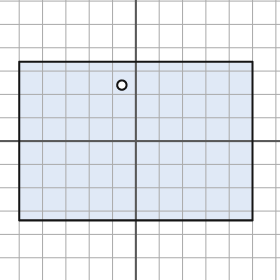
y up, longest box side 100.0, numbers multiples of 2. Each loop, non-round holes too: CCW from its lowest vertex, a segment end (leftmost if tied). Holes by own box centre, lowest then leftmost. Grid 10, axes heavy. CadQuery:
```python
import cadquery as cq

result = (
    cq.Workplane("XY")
    .moveTo(-50.0, -34.0)
    .lineTo(50.0, -34.0)
    .lineTo(50.0, 34.0)
    .lineTo(-50.0, 34.0)
    .close()
    .moveTo(-6.0, 24.0)
    .circle(2.0)
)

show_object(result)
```